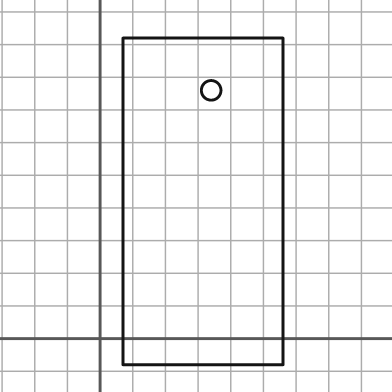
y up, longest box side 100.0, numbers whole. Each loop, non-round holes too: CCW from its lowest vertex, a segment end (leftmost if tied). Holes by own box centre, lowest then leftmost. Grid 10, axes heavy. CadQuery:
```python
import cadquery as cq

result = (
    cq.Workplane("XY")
    .moveTo(7.0, -8.0)
    .lineTo(56.0, -8.0)
    .lineTo(56.0, 92.0)
    .lineTo(7.0, 92.0)
    .close()
    .moveTo(34.0, 76.0)
    .circle(3.0)
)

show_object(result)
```